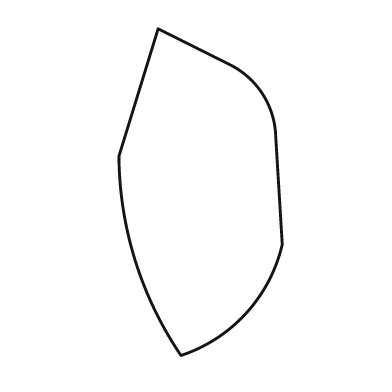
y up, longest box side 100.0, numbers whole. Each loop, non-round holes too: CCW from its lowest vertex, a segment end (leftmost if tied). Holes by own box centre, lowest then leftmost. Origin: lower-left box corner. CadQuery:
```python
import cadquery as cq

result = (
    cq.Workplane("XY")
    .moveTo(19.0, 0.0)
    .threePointArc((39.0, 13.0), (50.0, 34.0))
    .lineTo(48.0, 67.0)
    .threePointArc((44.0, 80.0), (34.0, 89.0))
    .lineTo(12.0, 100.0)
    .lineTo(0.0, 61.0)
    .threePointArc((5.0, 29.0), (19.0, 0.0))
    .close()
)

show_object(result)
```